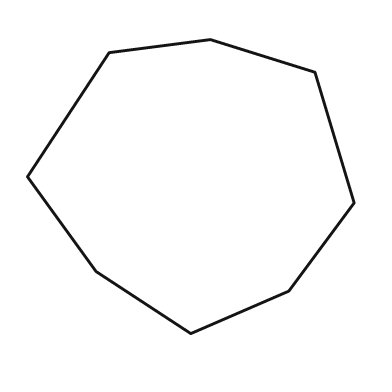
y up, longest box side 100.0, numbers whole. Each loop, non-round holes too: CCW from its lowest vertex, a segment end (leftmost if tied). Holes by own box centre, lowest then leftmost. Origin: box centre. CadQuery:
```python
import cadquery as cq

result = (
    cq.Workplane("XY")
    .moveTo(0.0, -45.0)
    .lineTo(30.0, -32.0)
    .lineTo(50.0, -5.0)
    .lineTo(38.0, 35.0)
    .lineTo(6.0, 45.0)
    .lineTo(-25.0, 41.0)
    .lineTo(-50.0, 3.0)
    .lineTo(-29.0, -26.0)
    .close()
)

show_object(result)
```